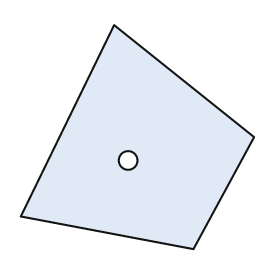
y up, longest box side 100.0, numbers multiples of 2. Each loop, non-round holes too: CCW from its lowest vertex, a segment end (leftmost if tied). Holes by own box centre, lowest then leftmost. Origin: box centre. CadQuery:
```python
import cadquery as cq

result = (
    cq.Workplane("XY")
    .moveTo(24.0, -48.0)
    .lineTo(50.0, 0.0)
    .lineTo(-10.0, 48.0)
    .lineTo(-50.0, -34.0)
    .close()
    .moveTo(-4.0, -10.0)
    .circle(4.0)
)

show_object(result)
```